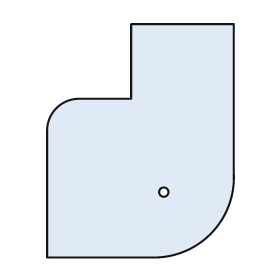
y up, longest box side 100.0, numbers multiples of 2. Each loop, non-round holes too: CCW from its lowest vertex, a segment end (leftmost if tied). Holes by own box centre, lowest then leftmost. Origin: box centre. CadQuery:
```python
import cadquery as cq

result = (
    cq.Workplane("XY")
    .moveTo(-40.0, -50.0)
    .lineTo(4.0, -50.0)
    .threePointArc((30.0, -40.0), (40.0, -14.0))
    .lineTo(40.0, 50.0)
    .lineTo(-4.0, 50.0)
    .lineTo(-4.0, 18.0)
    .lineTo(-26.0, 18.0)
    .threePointArc((-36.0, 14.0), (-40.0, 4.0))
    .close()
    .moveTo(10.0, -22.0)
    .circle(2.0)
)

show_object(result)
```